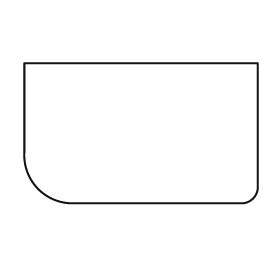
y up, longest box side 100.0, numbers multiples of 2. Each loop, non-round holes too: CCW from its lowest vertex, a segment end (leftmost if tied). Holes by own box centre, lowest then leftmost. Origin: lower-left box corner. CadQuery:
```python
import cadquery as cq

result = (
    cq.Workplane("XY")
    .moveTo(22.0, 0.0)
    .lineTo(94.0, 0.0)
    .threePointArc((98.0, 2.0), (100.0, 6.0))
    .lineTo(100.0, 60.0)
    .lineTo(0.0, 60.0)
    .lineTo(0.0, 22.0)
    .threePointArc((6.0, 6.0), (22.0, 0.0))
    .close()
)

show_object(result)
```